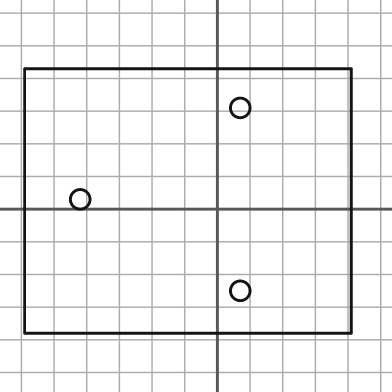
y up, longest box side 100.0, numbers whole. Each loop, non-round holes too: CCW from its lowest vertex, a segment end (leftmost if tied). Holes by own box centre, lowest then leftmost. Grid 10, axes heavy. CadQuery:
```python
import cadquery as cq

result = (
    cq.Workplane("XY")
    .moveTo(-59.0, -38.0)
    .lineTo(41.0, -38.0)
    .lineTo(41.0, 43.0)
    .lineTo(-59.0, 43.0)
    .close()
    .moveTo(7.0, -25.0)
    .circle(3.0)
    .moveTo(-42.0, 3.0)
    .circle(3.0)
    .moveTo(7.0, 31.0)
    .circle(3.0)
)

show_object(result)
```